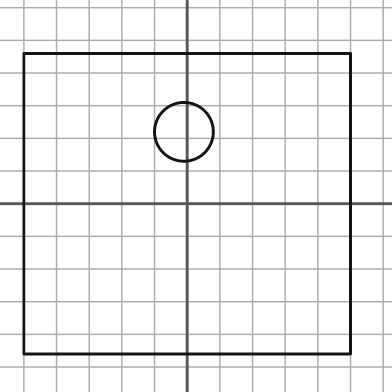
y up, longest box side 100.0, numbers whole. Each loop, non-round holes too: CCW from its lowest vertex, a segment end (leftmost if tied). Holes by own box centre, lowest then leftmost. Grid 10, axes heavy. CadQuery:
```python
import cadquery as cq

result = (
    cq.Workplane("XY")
    .moveTo(-50.0, -46.0)
    .lineTo(50.0, -46.0)
    .lineTo(50.0, 46.0)
    .lineTo(-50.0, 46.0)
    .close()
    .moveTo(-1.0, 22.0)
    .circle(9.0)
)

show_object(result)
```